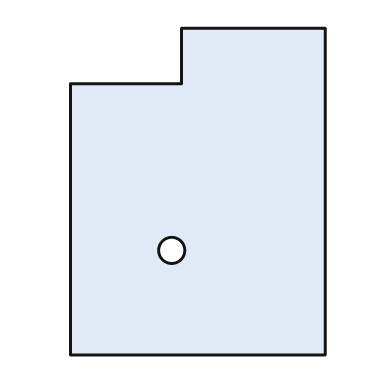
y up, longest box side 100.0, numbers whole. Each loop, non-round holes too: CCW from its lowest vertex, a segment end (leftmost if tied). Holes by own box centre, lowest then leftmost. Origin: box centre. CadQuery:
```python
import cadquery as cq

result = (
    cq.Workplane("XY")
    .moveTo(-39.0, -50.0)
    .lineTo(39.0, -50.0)
    .lineTo(39.0, 50.0)
    .lineTo(-5.0, 50.0)
    .lineTo(-5.0, 33.0)
    .lineTo(-39.0, 33.0)
    .close()
    .moveTo(-8.0, -18.0)
    .circle(4.0)
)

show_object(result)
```